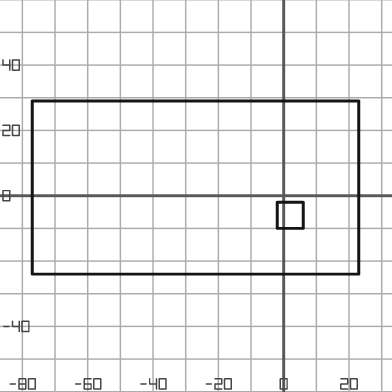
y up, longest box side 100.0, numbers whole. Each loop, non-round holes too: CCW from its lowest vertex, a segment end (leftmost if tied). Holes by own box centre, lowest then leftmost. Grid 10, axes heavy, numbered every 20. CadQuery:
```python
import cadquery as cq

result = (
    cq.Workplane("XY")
    .moveTo(-77.0, -24.0)
    .lineTo(23.0, -24.0)
    .lineTo(23.0, 29.0)
    .lineTo(-77.0, 29.0)
    .close()
    .moveTo(-2.0, -10.0)
    .lineTo(6.0, -10.0)
    .lineTo(6.0, -2.0)
    .lineTo(-2.0, -2.0)
    .close()
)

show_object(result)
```